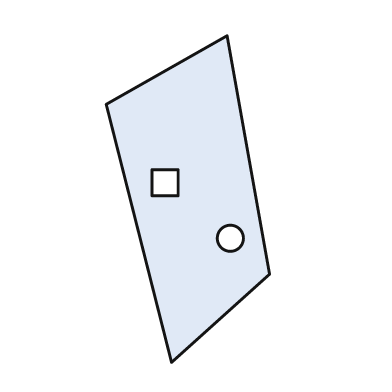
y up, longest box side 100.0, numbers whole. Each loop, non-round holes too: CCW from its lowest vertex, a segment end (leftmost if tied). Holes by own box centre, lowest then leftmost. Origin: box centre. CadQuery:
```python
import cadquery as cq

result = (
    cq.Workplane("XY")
    .moveTo(-5.0, -50.0)
    .lineTo(25.0, -23.0)
    .lineTo(12.0, 50.0)
    .lineTo(-25.0, 29.0)
    .close()
    .moveTo(13.0, -12.0)
    .circle(4.0)
    .moveTo(-11.0, 1.0)
    .lineTo(-3.0, 1.0)
    .lineTo(-3.0, 9.0)
    .lineTo(-11.0, 9.0)
    .close()
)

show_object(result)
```